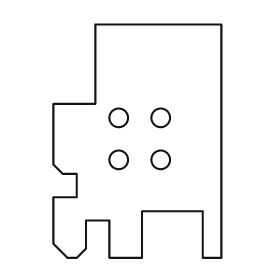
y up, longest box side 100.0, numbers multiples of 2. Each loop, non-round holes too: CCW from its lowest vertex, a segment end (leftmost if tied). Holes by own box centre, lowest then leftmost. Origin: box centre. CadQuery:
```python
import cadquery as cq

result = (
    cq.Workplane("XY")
    .moveTo(-30.0, -50.0)
    .lineTo(-26.0, -50.0)
    .lineTo(-22.0, -46.0)
    .lineTo(-22.0, -34.0)
    .lineTo(-12.0, -34.0)
    .lineTo(-12.0, -50.0)
    .lineTo(2.0, -50.0)
    .lineTo(2.0, -30.0)
    .lineTo(28.0, -30.0)
    .lineTo(28.0, -50.0)
    .lineTo(36.0, -50.0)
    .lineTo(36.0, 50.0)
    .lineTo(-18.0, 50.0)
    .lineTo(-18.0, 16.0)
    .lineTo(-36.0, 16.0)
    .lineTo(-36.0, -10.0)
    .lineTo(-32.0, -14.0)
    .lineTo(-26.0, -14.0)
    .lineTo(-26.0, -24.0)
    .lineTo(-36.0, -24.0)
    .lineTo(-36.0, -44.0)
    .close()
    .moveTo(-8.0, -8.0)
    .circle(4.0)
    .moveTo(10.0, -8.0)
    .circle(4.0)
    .moveTo(-8.0, 10.0)
    .circle(4.0)
    .moveTo(10.0, 10.0)
    .circle(4.0)
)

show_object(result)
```